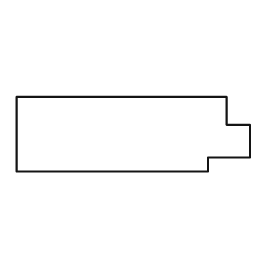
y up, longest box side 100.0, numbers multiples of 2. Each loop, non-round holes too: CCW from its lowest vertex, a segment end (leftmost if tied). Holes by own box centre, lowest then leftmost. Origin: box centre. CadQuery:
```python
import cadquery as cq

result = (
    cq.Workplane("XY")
    .moveTo(-50.0, -16.0)
    .lineTo(32.0, -16.0)
    .lineTo(32.0, -10.0)
    .lineTo(50.0, -10.0)
    .lineTo(50.0, 4.0)
    .lineTo(40.0, 4.0)
    .lineTo(40.0, 16.0)
    .lineTo(-50.0, 16.0)
    .close()
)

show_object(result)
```